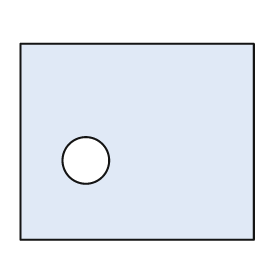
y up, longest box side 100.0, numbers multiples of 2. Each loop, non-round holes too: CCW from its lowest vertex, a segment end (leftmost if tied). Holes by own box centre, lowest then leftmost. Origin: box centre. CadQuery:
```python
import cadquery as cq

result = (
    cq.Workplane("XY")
    .moveTo(-50.0, -42.0)
    .lineTo(50.0, -42.0)
    .lineTo(50.0, 42.0)
    .lineTo(-50.0, 42.0)
    .close()
    .moveTo(-22.0, -8.0)
    .circle(10.0)
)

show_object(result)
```